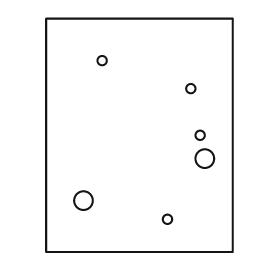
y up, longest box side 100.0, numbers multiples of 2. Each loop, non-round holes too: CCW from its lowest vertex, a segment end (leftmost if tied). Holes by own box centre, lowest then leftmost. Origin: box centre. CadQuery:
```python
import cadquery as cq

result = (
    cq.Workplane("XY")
    .moveTo(-40.0, -50.0)
    .lineTo(40.0, -50.0)
    .lineTo(40.0, 50.0)
    .lineTo(-40.0, 50.0)
    .close()
    .moveTo(12.0, -36.0)
    .circle(2.0)
    .moveTo(-24.0, -28.0)
    .circle(4.0)
    .moveTo(28.0, -10.0)
    .circle(4.0)
    .moveTo(26.0, 0.0)
    .circle(2.0)
    .moveTo(22.0, 20.0)
    .circle(2.0)
    .moveTo(-16.0, 32.0)
    .circle(2.0)
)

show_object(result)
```